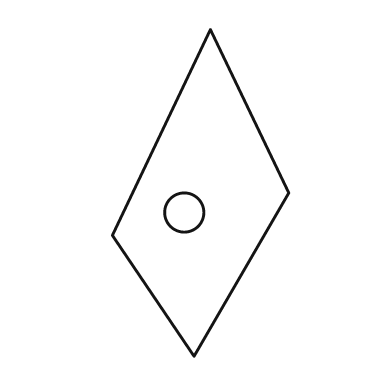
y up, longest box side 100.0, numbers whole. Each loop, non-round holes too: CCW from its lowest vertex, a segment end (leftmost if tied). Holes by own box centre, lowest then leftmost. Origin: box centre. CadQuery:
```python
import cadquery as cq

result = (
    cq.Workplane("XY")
    .moveTo(-2.0, -50.0)
    .lineTo(27.0, 0.0)
    .lineTo(3.0, 50.0)
    .lineTo(-27.0, -13.0)
    .close()
    .moveTo(-5.0, -6.0)
    .circle(6.0)
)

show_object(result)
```